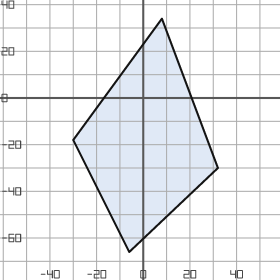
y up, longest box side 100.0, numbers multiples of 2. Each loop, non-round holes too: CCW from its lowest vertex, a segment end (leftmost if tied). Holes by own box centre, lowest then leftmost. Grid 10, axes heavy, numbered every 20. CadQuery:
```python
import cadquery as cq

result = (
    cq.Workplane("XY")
    .moveTo(-6.0, -66.0)
    .lineTo(32.0, -30.0)
    .lineTo(8.0, 34.0)
    .lineTo(-30.0, -18.0)
    .close()
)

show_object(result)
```